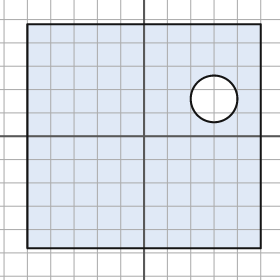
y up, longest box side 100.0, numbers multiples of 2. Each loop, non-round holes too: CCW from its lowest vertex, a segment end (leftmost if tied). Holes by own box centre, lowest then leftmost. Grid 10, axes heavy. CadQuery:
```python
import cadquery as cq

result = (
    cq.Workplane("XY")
    .moveTo(-50.0, -48.0)
    .lineTo(50.0, -48.0)
    .lineTo(50.0, 48.0)
    .lineTo(-50.0, 48.0)
    .close()
    .moveTo(30.0, 16.0)
    .circle(10.0)
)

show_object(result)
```